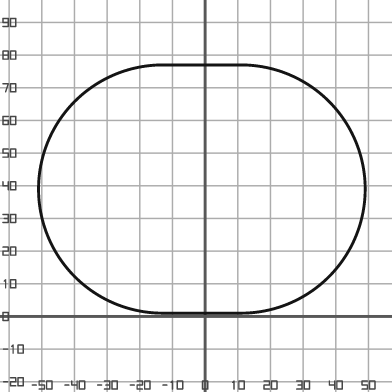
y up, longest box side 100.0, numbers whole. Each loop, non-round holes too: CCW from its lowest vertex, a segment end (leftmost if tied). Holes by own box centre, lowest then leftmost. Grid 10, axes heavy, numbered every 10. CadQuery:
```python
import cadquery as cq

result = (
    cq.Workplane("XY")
    .moveTo(-13.0, 1.0)
    .lineTo(11.0, 1.0)
    .threePointArc((49.0, 39.0), (11.0, 77.0))
    .lineTo(-13.0, 77.0)
    .threePointArc((-51.0, 39.0), (-13.0, 1.0))
    .close()
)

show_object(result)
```